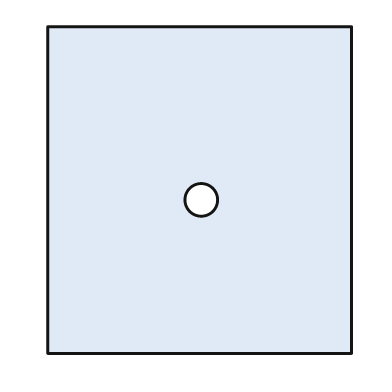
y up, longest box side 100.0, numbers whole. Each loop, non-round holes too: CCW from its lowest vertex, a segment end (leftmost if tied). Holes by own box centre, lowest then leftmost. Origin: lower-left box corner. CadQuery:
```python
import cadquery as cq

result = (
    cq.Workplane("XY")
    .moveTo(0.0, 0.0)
    .lineTo(93.0, 0.0)
    .lineTo(93.0, 100.0)
    .lineTo(0.0, 100.0)
    .close()
    .moveTo(47.0, 47.0)
    .circle(5.0)
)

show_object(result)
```